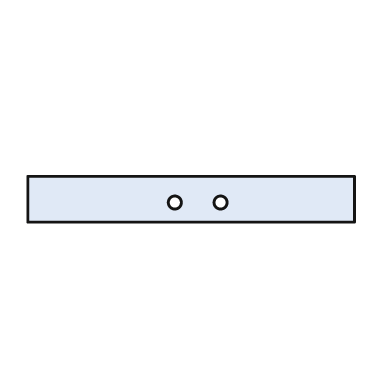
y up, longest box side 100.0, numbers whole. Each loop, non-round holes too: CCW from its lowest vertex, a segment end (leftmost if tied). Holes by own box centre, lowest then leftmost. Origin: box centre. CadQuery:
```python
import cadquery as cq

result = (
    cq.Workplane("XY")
    .moveTo(-50.0, -7.0)
    .lineTo(50.0, -7.0)
    .lineTo(50.0, 7.0)
    .lineTo(-50.0, 7.0)
    .close()
    .moveTo(-5.0, -1.0)
    .circle(2.0)
    .moveTo(9.0, -1.0)
    .circle(2.0)
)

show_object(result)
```